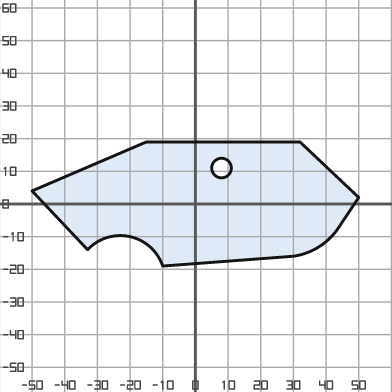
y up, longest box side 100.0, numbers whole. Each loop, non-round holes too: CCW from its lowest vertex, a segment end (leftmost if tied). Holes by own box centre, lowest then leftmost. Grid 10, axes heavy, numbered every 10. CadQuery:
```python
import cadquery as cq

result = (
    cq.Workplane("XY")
    .moveTo(-10.0, -19.0)
    .lineTo(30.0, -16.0)
    .threePointArc((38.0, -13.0), (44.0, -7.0))
    .lineTo(50.0, 2.0)
    .lineTo(32.0, 19.0)
    .lineTo(-15.0, 19.0)
    .lineTo(-50.0, 4.0)
    .lineTo(-33.0, -14.0)
    .threePointArc((-20.0, -10.0), (-10.0, -19.0))
    .close()
    .moveTo(8.0, 11.0)
    .circle(3.0)
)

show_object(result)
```